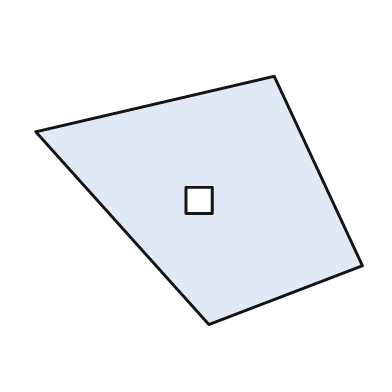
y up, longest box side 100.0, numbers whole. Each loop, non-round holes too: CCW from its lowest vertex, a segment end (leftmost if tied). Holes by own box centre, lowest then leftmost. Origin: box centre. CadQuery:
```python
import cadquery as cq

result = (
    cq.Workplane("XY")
    .moveTo(3.0, -38.0)
    .lineTo(50.0, -20.0)
    .lineTo(23.0, 38.0)
    .lineTo(-50.0, 21.0)
    .close()
    .moveTo(-4.0, -4.0)
    .lineTo(4.0, -4.0)
    .lineTo(4.0, 4.0)
    .lineTo(-4.0, 4.0)
    .close()
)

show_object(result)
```